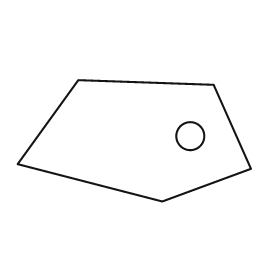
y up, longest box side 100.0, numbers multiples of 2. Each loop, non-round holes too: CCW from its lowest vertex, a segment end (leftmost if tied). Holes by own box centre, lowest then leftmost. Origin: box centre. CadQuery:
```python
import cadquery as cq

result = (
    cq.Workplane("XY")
    .moveTo(12.0, -26.0)
    .lineTo(50.0, -12.0)
    .lineTo(34.0, 24.0)
    .lineTo(-24.0, 26.0)
    .lineTo(-50.0, -10.0)
    .close()
    .moveTo(24.0, 2.0)
    .circle(6.0)
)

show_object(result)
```